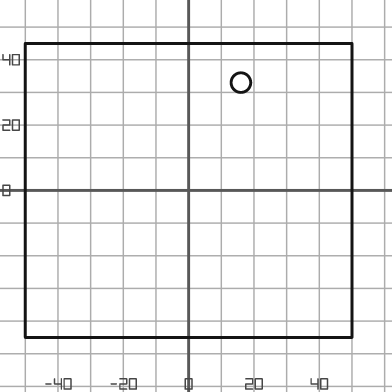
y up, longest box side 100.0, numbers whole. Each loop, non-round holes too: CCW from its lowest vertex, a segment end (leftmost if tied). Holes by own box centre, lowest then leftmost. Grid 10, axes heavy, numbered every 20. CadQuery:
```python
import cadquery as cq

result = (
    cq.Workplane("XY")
    .moveTo(-50.0, -45.0)
    .lineTo(50.0, -45.0)
    .lineTo(50.0, 45.0)
    .lineTo(-50.0, 45.0)
    .close()
    .moveTo(16.0, 33.0)
    .circle(3.0)
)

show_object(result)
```